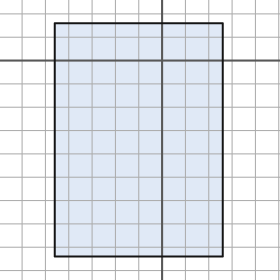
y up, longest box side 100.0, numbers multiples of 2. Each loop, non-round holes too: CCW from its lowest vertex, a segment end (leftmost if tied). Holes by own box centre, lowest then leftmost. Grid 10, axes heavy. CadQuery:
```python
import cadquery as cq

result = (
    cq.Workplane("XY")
    .moveTo(-46.0, -84.0)
    .lineTo(26.0, -84.0)
    .lineTo(26.0, 16.0)
    .lineTo(-46.0, 16.0)
    .close()
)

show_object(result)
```